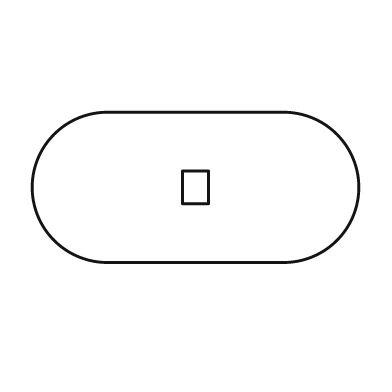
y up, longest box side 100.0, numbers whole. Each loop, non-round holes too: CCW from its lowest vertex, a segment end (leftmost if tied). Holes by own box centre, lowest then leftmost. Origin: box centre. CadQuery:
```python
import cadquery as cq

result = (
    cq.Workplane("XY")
    .moveTo(-27.0, -23.0)
    .lineTo(27.0, -23.0)
    .threePointArc((50.0, 0.0), (27.0, 23.0))
    .lineTo(-27.0, 23.0)
    .threePointArc((-50.0, 0.0), (-27.0, -23.0))
    .close()
    .moveTo(-4.0, -5.0)
    .lineTo(4.0, -5.0)
    .lineTo(4.0, 5.0)
    .lineTo(-4.0, 5.0)
    .close()
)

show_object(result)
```